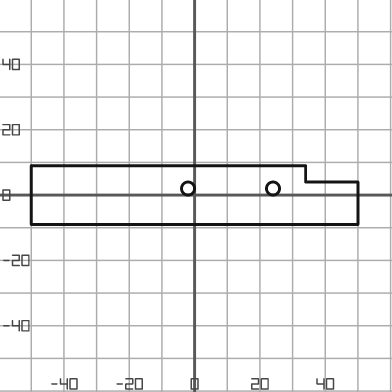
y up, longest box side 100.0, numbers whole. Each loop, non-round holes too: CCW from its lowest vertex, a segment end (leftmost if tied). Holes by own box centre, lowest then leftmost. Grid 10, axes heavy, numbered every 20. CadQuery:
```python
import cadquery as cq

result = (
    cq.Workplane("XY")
    .moveTo(-50.0, -9.0)
    .lineTo(50.0, -9.0)
    .lineTo(50.0, 4.0)
    .lineTo(34.0, 4.0)
    .lineTo(34.0, 9.0)
    .lineTo(-50.0, 9.0)
    .close()
    .moveTo(-2.0, 2.0)
    .circle(2.0)
    .moveTo(24.0, 2.0)
    .circle(2.0)
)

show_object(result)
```